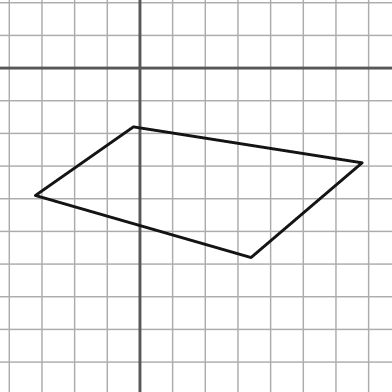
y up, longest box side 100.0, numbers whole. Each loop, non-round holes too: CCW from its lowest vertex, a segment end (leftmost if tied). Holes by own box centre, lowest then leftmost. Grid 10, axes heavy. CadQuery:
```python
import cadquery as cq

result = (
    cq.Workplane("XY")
    .moveTo(34.0, -58.0)
    .lineTo(68.0, -29.0)
    .lineTo(-2.0, -18.0)
    .lineTo(-32.0, -39.0)
    .close()
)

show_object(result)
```